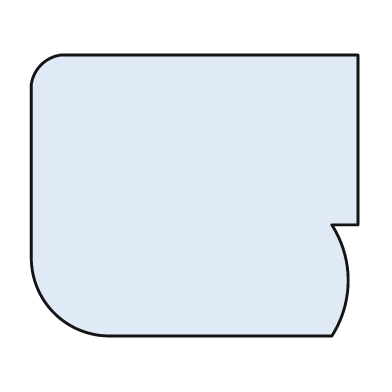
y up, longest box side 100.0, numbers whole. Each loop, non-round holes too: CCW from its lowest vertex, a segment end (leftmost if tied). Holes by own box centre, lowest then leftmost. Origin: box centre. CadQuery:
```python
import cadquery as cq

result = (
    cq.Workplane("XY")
    .moveTo(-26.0, -43.0)
    .lineTo(42.0, -43.0)
    .threePointArc((47.0, -26.0), (42.0, -9.0))
    .lineTo(50.0, -9.0)
    .lineTo(50.0, 43.0)
    .lineTo(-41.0, 43.0)
    .threePointArc((-47.0, 40.0), (-50.0, 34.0))
    .lineTo(-50.0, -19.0)
    .threePointArc((-43.0, -36.0), (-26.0, -43.0))
    .close()
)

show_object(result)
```